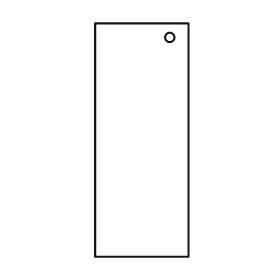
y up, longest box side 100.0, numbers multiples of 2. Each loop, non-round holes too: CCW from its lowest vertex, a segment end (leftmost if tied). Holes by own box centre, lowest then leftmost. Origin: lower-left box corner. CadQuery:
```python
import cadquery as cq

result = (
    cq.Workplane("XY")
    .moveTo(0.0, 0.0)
    .lineTo(40.0, 0.0)
    .lineTo(40.0, 100.0)
    .lineTo(0.0, 100.0)
    .close()
    .moveTo(32.0, 94.0)
    .circle(2.0)
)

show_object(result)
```